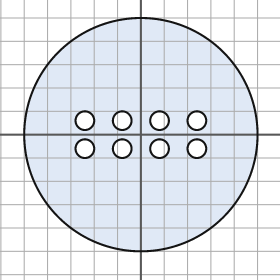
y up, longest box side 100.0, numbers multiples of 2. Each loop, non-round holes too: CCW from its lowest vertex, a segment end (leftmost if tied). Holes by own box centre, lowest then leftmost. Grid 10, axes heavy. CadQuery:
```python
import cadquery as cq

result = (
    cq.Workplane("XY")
    .moveTo(0.0, 0.0)
    .circle(50.0)
    .moveTo(-24.0, -6.0)
    .circle(4.0)
    .moveTo(-8.0, -6.0)
    .circle(4.0)
    .moveTo(8.0, -6.0)
    .circle(4.0)
    .moveTo(24.0, -6.0)
    .circle(4.0)
    .moveTo(-24.0, 6.0)
    .circle(4.0)
    .moveTo(-8.0, 6.0)
    .circle(4.0)
    .moveTo(8.0, 6.0)
    .circle(4.0)
    .moveTo(24.0, 6.0)
    .circle(4.0)
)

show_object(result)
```